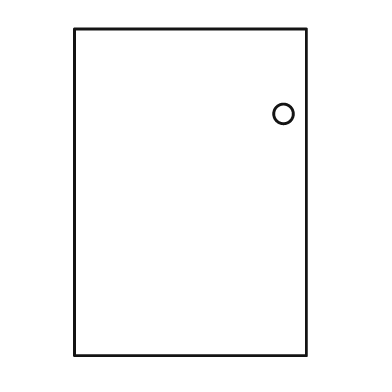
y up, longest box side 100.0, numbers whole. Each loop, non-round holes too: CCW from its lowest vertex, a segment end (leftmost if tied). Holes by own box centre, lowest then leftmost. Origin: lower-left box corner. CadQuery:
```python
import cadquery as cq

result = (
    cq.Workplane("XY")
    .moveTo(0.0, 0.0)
    .lineTo(71.0, 0.0)
    .lineTo(71.0, 100.0)
    .lineTo(0.0, 100.0)
    .close()
    .moveTo(64.0, 74.0)
    .circle(3.0)
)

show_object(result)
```